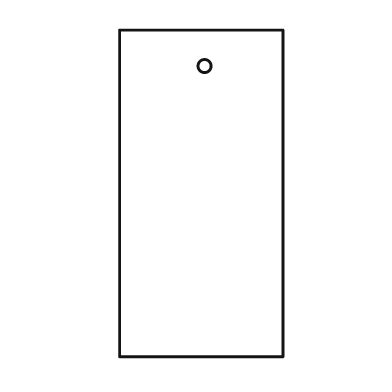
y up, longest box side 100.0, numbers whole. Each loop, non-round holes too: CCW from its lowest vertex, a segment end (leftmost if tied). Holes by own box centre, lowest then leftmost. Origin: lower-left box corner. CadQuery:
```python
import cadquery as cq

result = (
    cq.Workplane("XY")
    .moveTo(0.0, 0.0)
    .lineTo(50.0, 0.0)
    .lineTo(50.0, 100.0)
    .lineTo(0.0, 100.0)
    .close()
    .moveTo(26.0, 89.0)
    .circle(2.0)
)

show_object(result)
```